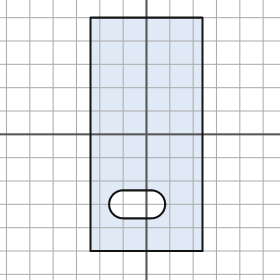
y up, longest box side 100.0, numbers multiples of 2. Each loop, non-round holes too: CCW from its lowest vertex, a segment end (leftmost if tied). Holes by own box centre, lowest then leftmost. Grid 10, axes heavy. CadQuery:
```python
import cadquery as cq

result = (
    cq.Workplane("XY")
    .moveTo(-24.0, -50.0)
    .lineTo(24.0, -50.0)
    .lineTo(24.0, 50.0)
    .lineTo(-24.0, 50.0)
    .close()
    .moveTo(-10.0, -36.0)
    .lineTo(2.0, -36.0)
    .threePointArc((8.0, -30.0), (2.0, -24.0))
    .lineTo(-10.0, -24.0)
    .threePointArc((-16.0, -30.0), (-10.0, -36.0))
    .close()
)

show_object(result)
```